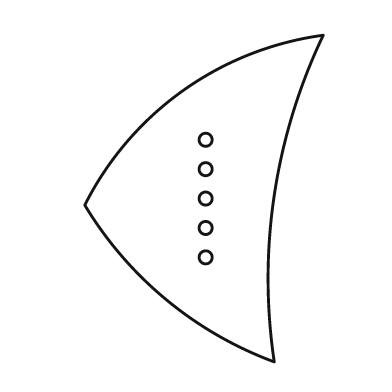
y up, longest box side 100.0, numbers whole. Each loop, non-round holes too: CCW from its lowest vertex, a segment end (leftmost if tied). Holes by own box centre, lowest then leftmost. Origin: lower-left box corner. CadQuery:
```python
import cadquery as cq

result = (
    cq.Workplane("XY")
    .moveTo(58.0, 0.0)
    .threePointArc((58.0, 51.0), (73.0, 100.0))
    .threePointArc((30.0, 83.0), (0.0, 48.0))
    .threePointArc((25.0, 19.0), (58.0, 0.0))
    .close()
    .moveTo(37.0, 32.0)
    .circle(2.0)
    .moveTo(37.0, 41.0)
    .circle(2.0)
    .moveTo(37.0, 50.0)
    .circle(2.0)
    .moveTo(37.0, 59.0)
    .circle(2.0)
    .moveTo(37.0, 68.0)
    .circle(2.0)
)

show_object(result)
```